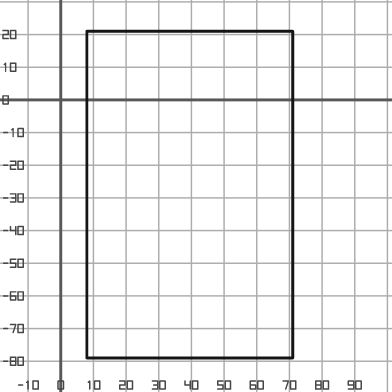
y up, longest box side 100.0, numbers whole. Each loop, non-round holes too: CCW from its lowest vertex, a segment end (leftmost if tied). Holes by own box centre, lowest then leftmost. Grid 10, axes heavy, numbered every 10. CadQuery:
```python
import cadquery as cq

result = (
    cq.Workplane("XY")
    .moveTo(8.0, -79.0)
    .lineTo(71.0, -79.0)
    .lineTo(71.0, 21.0)
    .lineTo(8.0, 21.0)
    .close()
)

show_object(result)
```